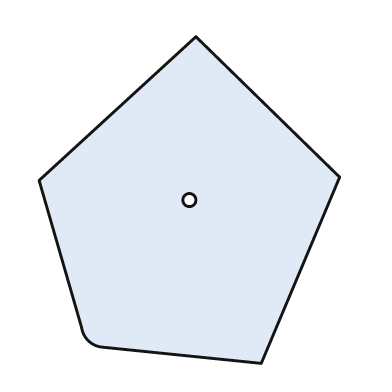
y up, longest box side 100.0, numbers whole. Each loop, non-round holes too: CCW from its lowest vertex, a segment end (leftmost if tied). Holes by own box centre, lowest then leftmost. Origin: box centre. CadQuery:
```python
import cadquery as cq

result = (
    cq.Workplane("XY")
    .moveTo(22.0, -50.0)
    .lineTo(46.0, 7.0)
    .lineTo(2.0, 50.0)
    .lineTo(-46.0, 6.0)
    .lineTo(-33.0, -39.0)
    .threePointArc((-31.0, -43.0), (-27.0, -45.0))
    .close()
    .moveTo(0.0, 0.0)
    .circle(2.0)
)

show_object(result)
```